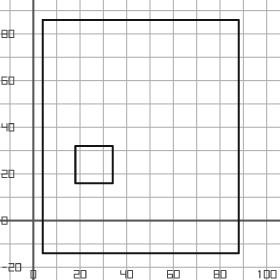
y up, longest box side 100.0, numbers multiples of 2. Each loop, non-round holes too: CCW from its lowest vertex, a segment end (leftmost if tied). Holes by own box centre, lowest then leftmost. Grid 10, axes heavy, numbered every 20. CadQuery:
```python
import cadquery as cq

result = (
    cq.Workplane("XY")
    .moveTo(4.0, -14.0)
    .lineTo(88.0, -14.0)
    .lineTo(88.0, 86.0)
    .lineTo(4.0, 86.0)
    .close()
    .moveTo(18.0, 16.0)
    .lineTo(34.0, 16.0)
    .lineTo(34.0, 32.0)
    .lineTo(18.0, 32.0)
    .close()
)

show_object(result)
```